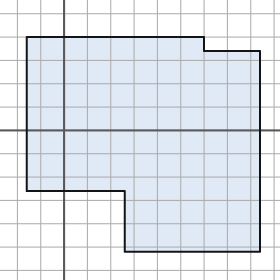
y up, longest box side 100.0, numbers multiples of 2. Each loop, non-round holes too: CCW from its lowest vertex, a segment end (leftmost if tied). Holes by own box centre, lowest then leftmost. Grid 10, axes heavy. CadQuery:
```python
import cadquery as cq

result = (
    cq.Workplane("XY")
    .moveTo(26.0, -52.0)
    .lineTo(84.0, -52.0)
    .lineTo(84.0, 34.0)
    .lineTo(60.0, 34.0)
    .lineTo(60.0, 40.0)
    .lineTo(-16.0, 40.0)
    .lineTo(-16.0, -26.0)
    .lineTo(26.0, -26.0)
    .close()
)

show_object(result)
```